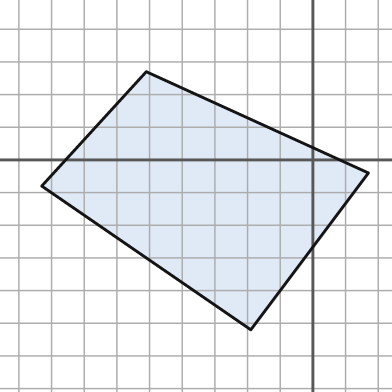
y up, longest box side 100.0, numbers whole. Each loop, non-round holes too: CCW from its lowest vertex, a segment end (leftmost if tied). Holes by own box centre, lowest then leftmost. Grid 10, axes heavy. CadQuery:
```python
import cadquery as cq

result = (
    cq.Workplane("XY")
    .moveTo(-19.0, -52.0)
    .lineTo(17.0, -4.0)
    .lineTo(-51.0, 27.0)
    .lineTo(-83.0, -8.0)
    .close()
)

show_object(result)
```